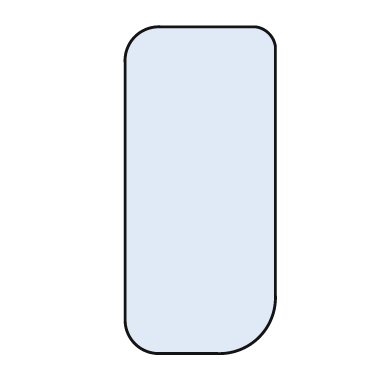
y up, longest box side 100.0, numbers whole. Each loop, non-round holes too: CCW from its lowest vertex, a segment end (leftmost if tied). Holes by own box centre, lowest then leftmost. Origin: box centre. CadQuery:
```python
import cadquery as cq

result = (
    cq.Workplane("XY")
    .moveTo(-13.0, -50.0)
    .lineTo(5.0, -50.0)
    .threePointArc((18.0, -45.0), (23.0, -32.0))
    .lineTo(23.0, 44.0)
    .threePointArc((21.0, 48.0), (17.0, 50.0))
    .lineTo(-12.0, 50.0)
    .threePointArc((-20.0, 47.0), (-23.0, 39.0))
    .lineTo(-23.0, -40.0)
    .threePointArc((-20.0, -47.0), (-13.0, -50.0))
    .close()
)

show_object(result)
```